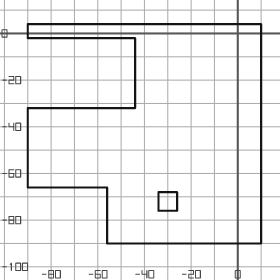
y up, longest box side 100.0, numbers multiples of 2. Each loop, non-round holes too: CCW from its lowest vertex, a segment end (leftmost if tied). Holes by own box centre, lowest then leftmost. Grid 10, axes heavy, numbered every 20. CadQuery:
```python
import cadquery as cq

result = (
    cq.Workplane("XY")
    .moveTo(-56.0, -90.0)
    .lineTo(10.0, -90.0)
    .lineTo(10.0, 4.0)
    .lineTo(-90.0, 4.0)
    .lineTo(-90.0, -2.0)
    .lineTo(-44.0, -2.0)
    .lineTo(-44.0, -32.0)
    .lineTo(-90.0, -32.0)
    .lineTo(-90.0, -66.0)
    .lineTo(-56.0, -66.0)
    .close()
    .moveTo(-34.0, -76.0)
    .lineTo(-26.0, -76.0)
    .lineTo(-26.0, -68.0)
    .lineTo(-34.0, -68.0)
    .close()
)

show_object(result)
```